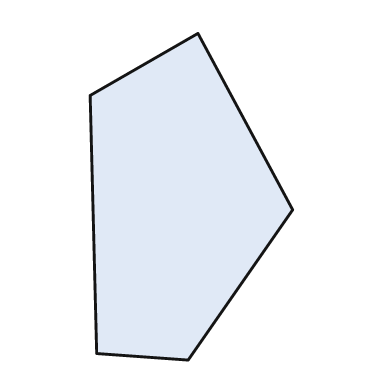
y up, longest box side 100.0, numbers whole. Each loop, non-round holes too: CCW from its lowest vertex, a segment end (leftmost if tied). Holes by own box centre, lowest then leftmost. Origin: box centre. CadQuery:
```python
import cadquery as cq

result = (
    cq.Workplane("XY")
    .moveTo(-1.0, -50.0)
    .lineTo(31.0, -4.0)
    .lineTo(2.0, 50.0)
    .lineTo(-31.0, 31.0)
    .lineTo(-29.0, -48.0)
    .close()
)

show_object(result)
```